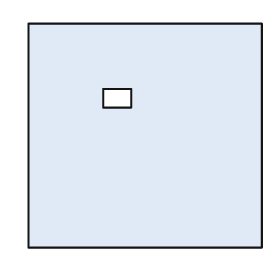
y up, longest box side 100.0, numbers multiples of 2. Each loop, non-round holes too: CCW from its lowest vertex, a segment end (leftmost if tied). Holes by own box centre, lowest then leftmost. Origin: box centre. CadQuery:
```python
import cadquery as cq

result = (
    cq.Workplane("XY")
    .moveTo(-50.0, -48.0)
    .lineTo(50.0, -48.0)
    .lineTo(50.0, 48.0)
    .lineTo(-50.0, 48.0)
    .close()
    .moveTo(-18.0, 12.0)
    .lineTo(-6.0, 12.0)
    .lineTo(-6.0, 20.0)
    .lineTo(-18.0, 20.0)
    .close()
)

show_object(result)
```